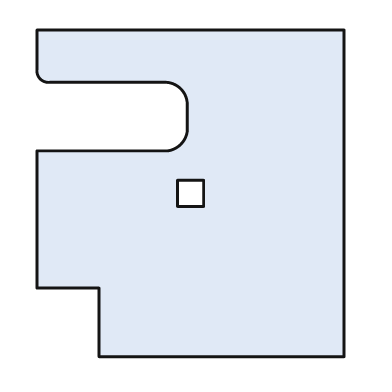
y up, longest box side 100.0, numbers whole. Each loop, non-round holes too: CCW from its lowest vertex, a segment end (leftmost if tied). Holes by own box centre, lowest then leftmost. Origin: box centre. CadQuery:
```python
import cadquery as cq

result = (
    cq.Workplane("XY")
    .moveTo(-28.0, -50.0)
    .lineTo(47.0, -50.0)
    .lineTo(47.0, 50.0)
    .lineTo(-47.0, 50.0)
    .lineTo(-47.0, 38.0)
    .threePointArc((-46.0, 35.0), (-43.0, 34.0))
    .lineTo(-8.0, 34.0)
    .threePointArc((-3.0, 32.0), (-1.0, 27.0))
    .lineTo(-1.0, 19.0)
    .threePointArc((-3.0, 15.0), (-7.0, 13.0))
    .lineTo(-47.0, 13.0)
    .lineTo(-47.0, -29.0)
    .lineTo(-28.0, -29.0)
    .close()
    .moveTo(-4.0, -4.0)
    .lineTo(4.0, -4.0)
    .lineTo(4.0, 4.0)
    .lineTo(-4.0, 4.0)
    .close()
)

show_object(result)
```